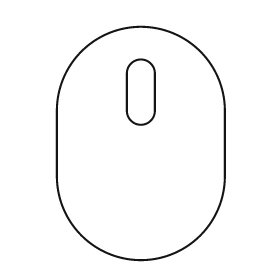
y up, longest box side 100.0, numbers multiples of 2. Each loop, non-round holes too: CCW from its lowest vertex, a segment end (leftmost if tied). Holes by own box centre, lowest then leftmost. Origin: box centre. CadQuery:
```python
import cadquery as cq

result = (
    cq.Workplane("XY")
    .moveTo(-36.0, -14.0)
    .threePointArc((0.0, -50.0), (36.0, -14.0))
    .lineTo(36.0, 14.0)
    .threePointArc((0.0, 50.0), (-36.0, 14.0))
    .close()
    .moveTo(-6.0, 14.0)
    .threePointArc((0.0, 8.0), (6.0, 14.0))
    .lineTo(6.0, 30.0)
    .threePointArc((0.0, 36.0), (-6.0, 30.0))
    .close()
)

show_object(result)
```